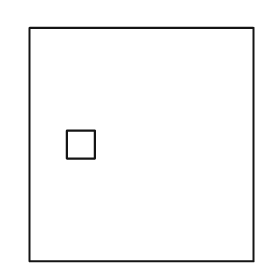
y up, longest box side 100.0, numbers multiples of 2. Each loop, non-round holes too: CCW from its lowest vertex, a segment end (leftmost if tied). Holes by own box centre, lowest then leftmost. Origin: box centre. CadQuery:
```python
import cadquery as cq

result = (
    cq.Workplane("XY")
    .moveTo(-48.0, -50.0)
    .lineTo(48.0, -50.0)
    .lineTo(48.0, 50.0)
    .lineTo(-48.0, 50.0)
    .close()
    .moveTo(-32.0, -6.0)
    .lineTo(-20.0, -6.0)
    .lineTo(-20.0, 6.0)
    .lineTo(-32.0, 6.0)
    .close()
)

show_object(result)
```